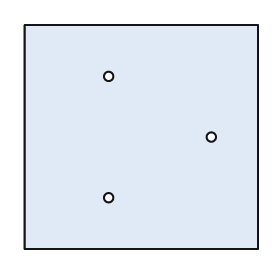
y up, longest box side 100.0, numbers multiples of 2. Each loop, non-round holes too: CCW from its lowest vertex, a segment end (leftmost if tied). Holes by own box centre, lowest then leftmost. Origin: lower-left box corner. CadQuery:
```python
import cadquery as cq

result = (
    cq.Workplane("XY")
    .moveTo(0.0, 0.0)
    .lineTo(100.0, 0.0)
    .lineTo(100.0, 96.0)
    .lineTo(0.0, 96.0)
    .close()
    .moveTo(36.0, 22.0)
    .circle(2.0)
    .moveTo(80.0, 48.0)
    .circle(2.0)
    .moveTo(36.0, 74.0)
    .circle(2.0)
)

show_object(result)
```